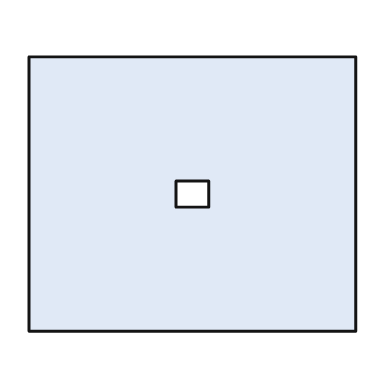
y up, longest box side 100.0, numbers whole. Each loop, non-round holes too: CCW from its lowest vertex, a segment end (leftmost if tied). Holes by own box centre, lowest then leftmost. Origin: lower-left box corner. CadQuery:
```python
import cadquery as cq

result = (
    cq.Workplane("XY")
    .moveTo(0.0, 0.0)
    .lineTo(100.0, 0.0)
    .lineTo(100.0, 84.0)
    .lineTo(0.0, 84.0)
    .close()
    .moveTo(45.0, 38.0)
    .lineTo(55.0, 38.0)
    .lineTo(55.0, 46.0)
    .lineTo(45.0, 46.0)
    .close()
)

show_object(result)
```